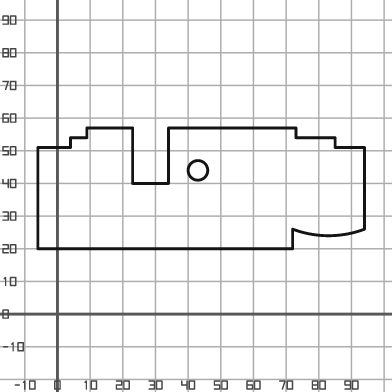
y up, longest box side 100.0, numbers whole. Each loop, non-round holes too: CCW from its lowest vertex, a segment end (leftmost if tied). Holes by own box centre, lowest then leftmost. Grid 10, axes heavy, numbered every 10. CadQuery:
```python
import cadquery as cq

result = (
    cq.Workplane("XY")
    .moveTo(-6.0, 20.0)
    .lineTo(72.0, 20.0)
    .lineTo(72.0, 26.0)
    .threePointArc((83.0, 24.0), (94.0, 26.0))
    .lineTo(94.0, 51.0)
    .lineTo(85.0, 51.0)
    .lineTo(85.0, 54.0)
    .lineTo(73.0, 54.0)
    .lineTo(73.0, 57.0)
    .lineTo(34.0, 57.0)
    .lineTo(34.0, 40.0)
    .lineTo(23.0, 40.0)
    .lineTo(23.0, 57.0)
    .lineTo(9.0, 57.0)
    .lineTo(9.0, 54.0)
    .lineTo(4.0, 54.0)
    .lineTo(4.0, 51.0)
    .lineTo(-6.0, 51.0)
    .close()
    .moveTo(43.0, 44.0)
    .circle(3.0)
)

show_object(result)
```